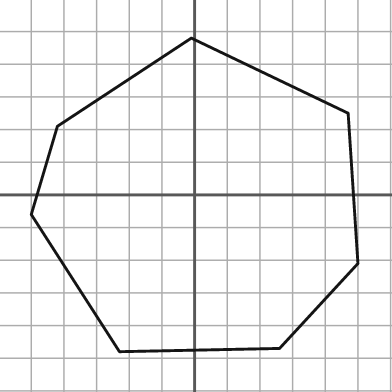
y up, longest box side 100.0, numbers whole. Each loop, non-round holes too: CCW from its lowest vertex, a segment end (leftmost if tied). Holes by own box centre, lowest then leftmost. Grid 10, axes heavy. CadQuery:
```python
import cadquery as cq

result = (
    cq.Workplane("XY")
    .moveTo(-23.0, -48.0)
    .lineTo(26.0, -47.0)
    .lineTo(50.0, -21.0)
    .lineTo(47.0, 25.0)
    .lineTo(-1.0, 48.0)
    .lineTo(-42.0, 21.0)
    .lineTo(-50.0, -6.0)
    .close()
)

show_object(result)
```